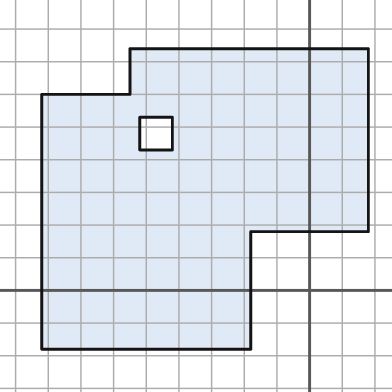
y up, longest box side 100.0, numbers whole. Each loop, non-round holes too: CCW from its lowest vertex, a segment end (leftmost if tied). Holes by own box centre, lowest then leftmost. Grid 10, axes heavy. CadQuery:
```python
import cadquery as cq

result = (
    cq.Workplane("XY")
    .moveTo(-82.0, -18.0)
    .lineTo(-18.0, -18.0)
    .lineTo(-18.0, 18.0)
    .lineTo(18.0, 18.0)
    .lineTo(18.0, 74.0)
    .lineTo(-55.0, 74.0)
    .lineTo(-55.0, 60.0)
    .lineTo(-82.0, 60.0)
    .close()
    .moveTo(-52.0, 43.0)
    .lineTo(-42.0, 43.0)
    .lineTo(-42.0, 53.0)
    .lineTo(-52.0, 53.0)
    .close()
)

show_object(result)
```